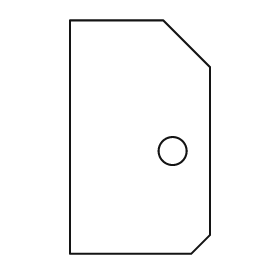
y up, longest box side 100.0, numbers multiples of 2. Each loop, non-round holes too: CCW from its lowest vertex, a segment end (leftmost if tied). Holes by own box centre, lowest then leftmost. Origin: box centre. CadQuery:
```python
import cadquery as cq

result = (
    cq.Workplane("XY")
    .moveTo(-30.0, -50.0)
    .lineTo(22.0, -50.0)
    .lineTo(30.0, -42.0)
    .lineTo(30.0, 30.0)
    .lineTo(10.0, 50.0)
    .lineTo(-30.0, 50.0)
    .close()
    .moveTo(14.0, -6.0)
    .circle(6.0)
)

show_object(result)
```